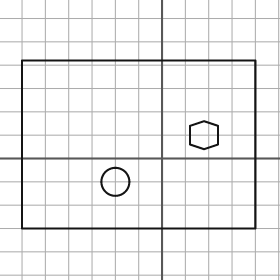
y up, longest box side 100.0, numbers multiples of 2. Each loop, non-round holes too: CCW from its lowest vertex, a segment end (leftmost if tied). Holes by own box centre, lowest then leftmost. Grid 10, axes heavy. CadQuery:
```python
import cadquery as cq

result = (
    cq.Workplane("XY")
    .moveTo(-60.0, -30.0)
    .lineTo(40.0, -30.0)
    .lineTo(40.0, 42.0)
    .lineTo(-60.0, 42.0)
    .close()
    .moveTo(-20.0, -10.0)
    .circle(6.0)
    .moveTo(18.0, 4.0)
    .lineTo(24.0, 6.0)
    .lineTo(24.0, 14.0)
    .lineTo(18.0, 16.0)
    .lineTo(12.0, 14.0)
    .lineTo(12.0, 6.0)
    .close()
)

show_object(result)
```